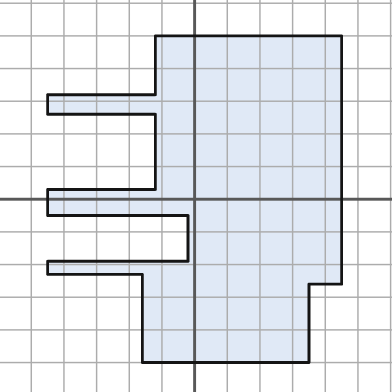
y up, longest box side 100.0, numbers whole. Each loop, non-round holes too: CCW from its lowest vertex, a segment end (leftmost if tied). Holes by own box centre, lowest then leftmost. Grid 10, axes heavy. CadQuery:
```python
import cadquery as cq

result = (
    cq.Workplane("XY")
    .moveTo(-16.0, -50.0)
    .lineTo(35.0, -50.0)
    .lineTo(35.0, -26.0)
    .lineTo(45.0, -26.0)
    .lineTo(45.0, 50.0)
    .lineTo(-12.0, 50.0)
    .lineTo(-12.0, 32.0)
    .lineTo(-45.0, 32.0)
    .lineTo(-45.0, 26.0)
    .lineTo(-12.0, 26.0)
    .lineTo(-12.0, 3.0)
    .lineTo(-45.0, 3.0)
    .lineTo(-45.0, -5.0)
    .lineTo(-2.0, -5.0)
    .lineTo(-2.0, -19.0)
    .lineTo(-45.0, -19.0)
    .lineTo(-45.0, -23.0)
    .lineTo(-16.0, -23.0)
    .close()
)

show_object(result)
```